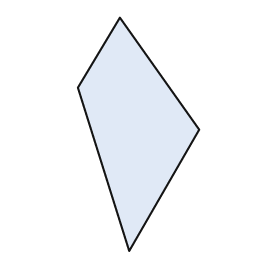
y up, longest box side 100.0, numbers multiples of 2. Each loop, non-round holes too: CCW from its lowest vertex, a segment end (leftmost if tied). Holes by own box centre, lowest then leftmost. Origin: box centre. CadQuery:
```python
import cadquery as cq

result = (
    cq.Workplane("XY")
    .moveTo(-4.0, -50.0)
    .lineTo(26.0, 2.0)
    .lineTo(-8.0, 50.0)
    .lineTo(-26.0, 20.0)
    .close()
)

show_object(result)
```